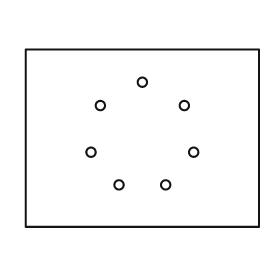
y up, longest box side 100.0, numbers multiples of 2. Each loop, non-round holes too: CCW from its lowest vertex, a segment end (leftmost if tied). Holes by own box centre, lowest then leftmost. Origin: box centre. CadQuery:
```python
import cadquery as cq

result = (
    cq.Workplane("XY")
    .moveTo(-50.0, -38.0)
    .lineTo(50.0, -38.0)
    .lineTo(50.0, 38.0)
    .lineTo(-50.0, 38.0)
    .close()
    .moveTo(-10.0, -20.0)
    .circle(2.0)
    .moveTo(10.0, -20.0)
    .circle(2.0)
    .moveTo(-22.0, -6.0)
    .circle(2.0)
    .moveTo(22.0, -6.0)
    .circle(2.0)
    .moveTo(-18.0, 14.0)
    .circle(2.0)
    .moveTo(18.0, 14.0)
    .circle(2.0)
    .moveTo(0.0, 24.0)
    .circle(2.0)
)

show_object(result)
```